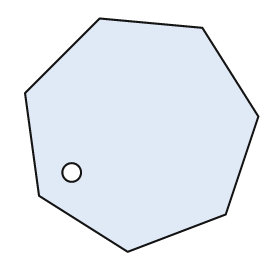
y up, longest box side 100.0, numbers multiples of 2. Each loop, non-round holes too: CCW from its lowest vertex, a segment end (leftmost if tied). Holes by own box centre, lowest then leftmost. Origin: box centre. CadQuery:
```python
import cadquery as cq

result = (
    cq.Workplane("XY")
    .moveTo(-6.0, -50.0)
    .lineTo(36.0, -34.0)
    .lineTo(50.0, 8.0)
    .lineTo(26.0, 46.0)
    .lineTo(-18.0, 50.0)
    .lineTo(-50.0, 18.0)
    .lineTo(-44.0, -26.0)
    .close()
    .moveTo(-30.0, -16.0)
    .circle(4.0)
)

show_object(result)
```